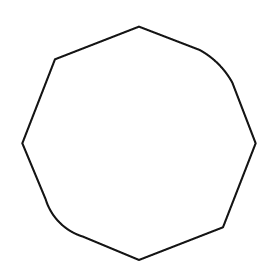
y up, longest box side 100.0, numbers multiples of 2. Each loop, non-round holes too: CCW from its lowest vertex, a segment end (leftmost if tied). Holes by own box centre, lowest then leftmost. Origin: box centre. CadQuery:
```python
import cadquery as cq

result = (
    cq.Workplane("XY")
    .moveTo(0.0, -50.0)
    .lineTo(36.0, -36.0)
    .lineTo(50.0, 0.0)
    .lineTo(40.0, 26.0)
    .threePointArc((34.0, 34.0), (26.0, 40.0))
    .lineTo(0.0, 50.0)
    .lineTo(-36.0, 36.0)
    .lineTo(-50.0, 0.0)
    .lineTo(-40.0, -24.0)
    .threePointArc((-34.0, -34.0), (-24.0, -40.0))
    .close()
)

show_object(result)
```